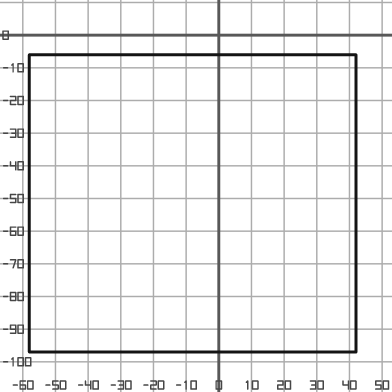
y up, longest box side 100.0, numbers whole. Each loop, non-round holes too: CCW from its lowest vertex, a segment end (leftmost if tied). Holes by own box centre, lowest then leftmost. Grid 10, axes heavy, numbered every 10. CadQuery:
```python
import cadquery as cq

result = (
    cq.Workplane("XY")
    .moveTo(-58.0, -97.0)
    .lineTo(42.0, -97.0)
    .lineTo(42.0, -6.0)
    .lineTo(-58.0, -6.0)
    .close()
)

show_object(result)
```